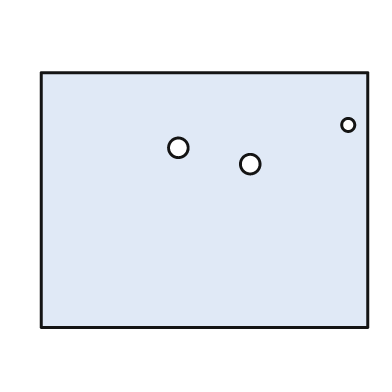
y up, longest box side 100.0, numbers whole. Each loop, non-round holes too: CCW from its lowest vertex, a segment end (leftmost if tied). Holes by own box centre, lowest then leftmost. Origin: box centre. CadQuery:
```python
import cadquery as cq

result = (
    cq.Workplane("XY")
    .moveTo(-50.0, -39.0)
    .lineTo(50.0, -39.0)
    .lineTo(50.0, 39.0)
    .lineTo(-50.0, 39.0)
    .close()
    .moveTo(14.0, 11.0)
    .circle(3.0)
    .moveTo(-8.0, 16.0)
    .circle(3.0)
    .moveTo(44.0, 23.0)
    .circle(2.0)
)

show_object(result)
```